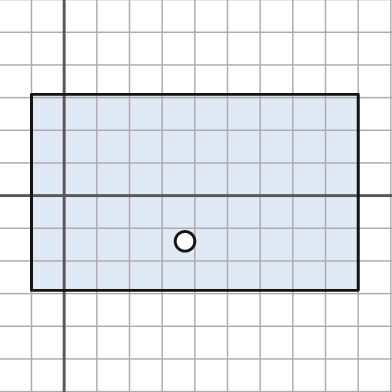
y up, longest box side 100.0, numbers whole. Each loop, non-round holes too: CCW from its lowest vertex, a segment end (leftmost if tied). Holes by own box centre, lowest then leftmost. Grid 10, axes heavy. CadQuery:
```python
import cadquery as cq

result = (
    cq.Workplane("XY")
    .moveTo(-10.0, -29.0)
    .lineTo(90.0, -29.0)
    .lineTo(90.0, 31.0)
    .lineTo(-10.0, 31.0)
    .close()
    .moveTo(37.0, -14.0)
    .circle(3.0)
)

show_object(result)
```